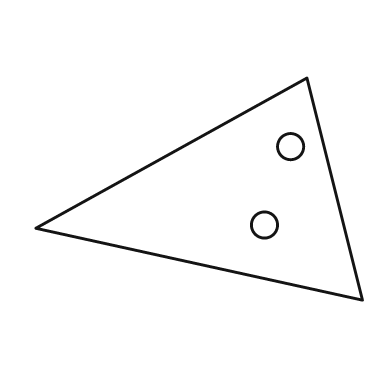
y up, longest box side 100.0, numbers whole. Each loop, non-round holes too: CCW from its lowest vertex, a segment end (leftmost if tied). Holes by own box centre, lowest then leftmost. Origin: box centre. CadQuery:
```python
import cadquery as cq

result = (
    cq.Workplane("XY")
    .moveTo(50.0, -34.0)
    .lineTo(33.0, 34.0)
    .lineTo(-50.0, -12.0)
    .close()
    .moveTo(20.0, -11.0)
    .circle(4.0)
    .moveTo(28.0, 13.0)
    .circle(4.0)
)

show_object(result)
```